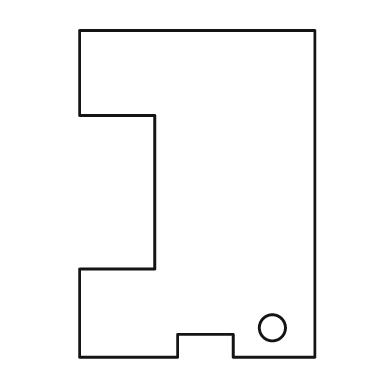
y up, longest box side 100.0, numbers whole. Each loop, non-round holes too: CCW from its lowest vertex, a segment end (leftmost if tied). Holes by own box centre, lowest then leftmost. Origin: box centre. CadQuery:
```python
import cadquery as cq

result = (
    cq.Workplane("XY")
    .moveTo(-36.0, -50.0)
    .lineTo(-6.0, -50.0)
    .lineTo(-6.0, -43.0)
    .lineTo(11.0, -43.0)
    .lineTo(11.0, -50.0)
    .lineTo(36.0, -50.0)
    .lineTo(36.0, 50.0)
    .lineTo(-36.0, 50.0)
    .lineTo(-36.0, 24.0)
    .lineTo(-13.0, 24.0)
    .lineTo(-13.0, -23.0)
    .lineTo(-36.0, -23.0)
    .close()
    .moveTo(23.0, -41.0)
    .circle(4.0)
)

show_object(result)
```